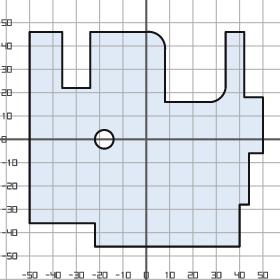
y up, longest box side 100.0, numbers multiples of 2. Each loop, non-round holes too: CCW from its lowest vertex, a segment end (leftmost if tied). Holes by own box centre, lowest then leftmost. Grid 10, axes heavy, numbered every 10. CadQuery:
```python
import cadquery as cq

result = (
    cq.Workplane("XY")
    .moveTo(-22.0, -46.0)
    .lineTo(40.0, -46.0)
    .lineTo(40.0, -28.0)
    .lineTo(44.0, -28.0)
    .lineTo(44.0, -6.0)
    .lineTo(50.0, -6.0)
    .lineTo(50.0, 18.0)
    .lineTo(42.0, 18.0)
    .lineTo(42.0, 46.0)
    .lineTo(34.0, 46.0)
    .lineTo(34.0, 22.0)
    .threePointArc((32.0, 18.0), (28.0, 16.0))
    .lineTo(8.0, 16.0)
    .lineTo(8.0, 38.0)
    .threePointArc((6.0, 44.0), (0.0, 46.0))
    .lineTo(-24.0, 46.0)
    .lineTo(-24.0, 22.0)
    .lineTo(-36.0, 22.0)
    .lineTo(-36.0, 46.0)
    .lineTo(-50.0, 46.0)
    .lineTo(-50.0, -36.0)
    .lineTo(-22.0, -36.0)
    .close()
    .moveTo(-18.0, 0.0)
    .circle(4.0)
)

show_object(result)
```